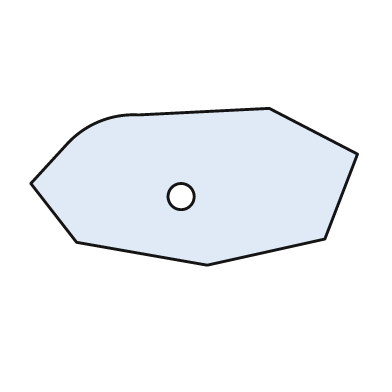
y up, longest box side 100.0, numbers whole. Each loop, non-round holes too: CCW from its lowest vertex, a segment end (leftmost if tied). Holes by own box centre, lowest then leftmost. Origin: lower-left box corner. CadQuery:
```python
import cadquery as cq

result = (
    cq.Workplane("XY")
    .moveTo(54.0, 0.0)
    .lineTo(90.0, 8.0)
    .lineTo(100.0, 34.0)
    .lineTo(73.0, 48.0)
    .lineTo(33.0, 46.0)
    .threePointArc((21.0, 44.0), (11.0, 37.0))
    .lineTo(0.0, 25.0)
    .lineTo(14.0, 7.0)
    .close()
    .moveTo(46.0, 21.0)
    .circle(4.0)
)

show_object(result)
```